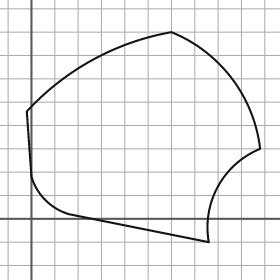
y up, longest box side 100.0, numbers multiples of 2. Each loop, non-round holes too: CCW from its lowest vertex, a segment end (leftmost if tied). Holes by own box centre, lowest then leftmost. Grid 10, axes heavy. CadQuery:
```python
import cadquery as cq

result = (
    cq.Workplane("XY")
    .moveTo(76.0, -10.0)
    .threePointArc((80.0, 14.0), (98.0, 30.0))
    .threePointArc((86.0, 60.0), (60.0, 80.0))
    .threePointArc((26.0, 68.0), (-2.0, 46.0))
    .lineTo(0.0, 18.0)
    .threePointArc((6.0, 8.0), (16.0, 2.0))
    .close()
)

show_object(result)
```